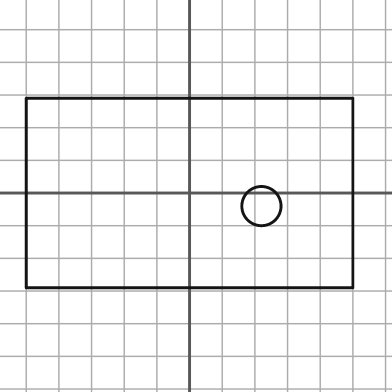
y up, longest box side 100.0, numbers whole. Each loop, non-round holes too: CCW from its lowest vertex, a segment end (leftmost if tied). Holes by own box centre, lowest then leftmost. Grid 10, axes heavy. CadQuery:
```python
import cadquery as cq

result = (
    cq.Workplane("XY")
    .moveTo(-50.0, -29.0)
    .lineTo(50.0, -29.0)
    .lineTo(50.0, 29.0)
    .lineTo(-50.0, 29.0)
    .close()
    .moveTo(22.0, -4.0)
    .circle(6.0)
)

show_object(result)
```